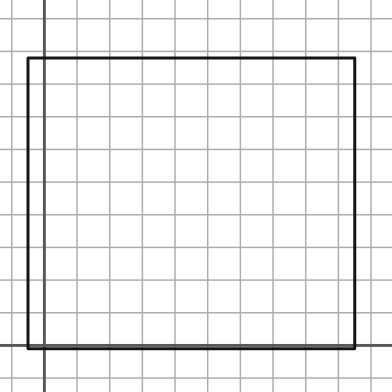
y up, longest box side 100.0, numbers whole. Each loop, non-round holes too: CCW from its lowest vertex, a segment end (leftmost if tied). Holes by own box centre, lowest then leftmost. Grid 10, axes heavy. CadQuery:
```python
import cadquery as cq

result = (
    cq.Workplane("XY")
    .moveTo(-5.0, -1.0)
    .lineTo(95.0, -1.0)
    .lineTo(95.0, 88.0)
    .lineTo(-5.0, 88.0)
    .close()
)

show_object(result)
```